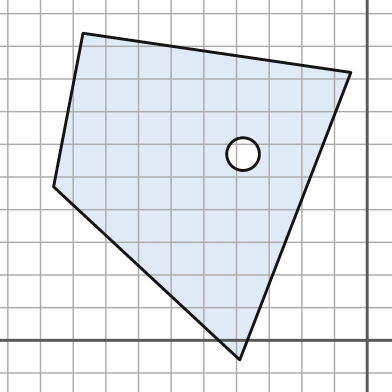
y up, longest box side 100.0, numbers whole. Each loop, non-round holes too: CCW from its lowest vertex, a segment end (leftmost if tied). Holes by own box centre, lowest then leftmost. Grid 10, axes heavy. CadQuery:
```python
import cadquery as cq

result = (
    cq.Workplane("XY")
    .moveTo(-39.0, -6.0)
    .lineTo(-5.0, 82.0)
    .lineTo(-87.0, 94.0)
    .lineTo(-96.0, 47.0)
    .close()
    .moveTo(-38.0, 57.0)
    .circle(5.0)
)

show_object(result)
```